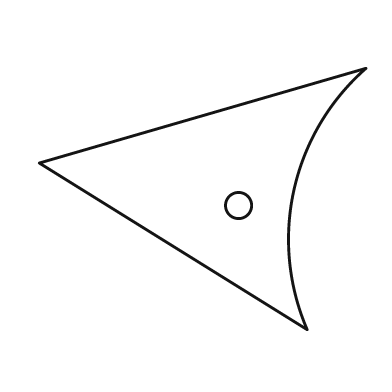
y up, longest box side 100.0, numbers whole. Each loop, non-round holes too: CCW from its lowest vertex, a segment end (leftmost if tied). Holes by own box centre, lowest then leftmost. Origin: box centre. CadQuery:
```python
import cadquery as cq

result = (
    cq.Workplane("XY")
    .moveTo(32.0, -40.0)
    .threePointArc((28.0, 3.0), (50.0, 40.0))
    .lineTo(-50.0, 11.0)
    .close()
    .moveTo(11.0, -2.0)
    .circle(4.0)
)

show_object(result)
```